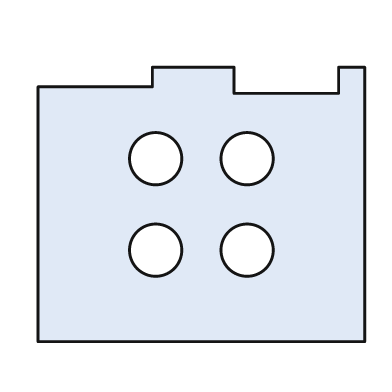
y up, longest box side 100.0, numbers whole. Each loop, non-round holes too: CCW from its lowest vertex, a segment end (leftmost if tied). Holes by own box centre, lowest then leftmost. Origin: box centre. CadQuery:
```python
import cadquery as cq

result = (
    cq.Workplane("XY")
    .moveTo(-50.0, -42.0)
    .lineTo(50.0, -42.0)
    .lineTo(50.0, 42.0)
    .lineTo(42.0, 42.0)
    .lineTo(42.0, 34.0)
    .lineTo(10.0, 34.0)
    .lineTo(10.0, 42.0)
    .lineTo(-15.0, 42.0)
    .lineTo(-15.0, 36.0)
    .lineTo(-50.0, 36.0)
    .close()
    .moveTo(-14.0, -14.0)
    .circle(8.0)
    .moveTo(14.0, -14.0)
    .circle(8.0)
    .moveTo(-14.0, 14.0)
    .circle(8.0)
    .moveTo(14.0, 14.0)
    .circle(8.0)
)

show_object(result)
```